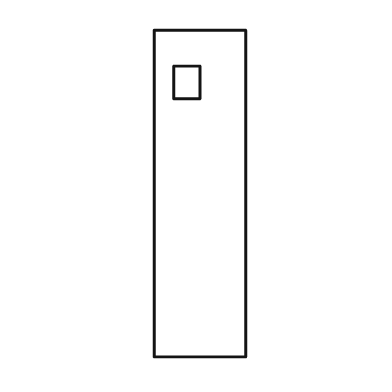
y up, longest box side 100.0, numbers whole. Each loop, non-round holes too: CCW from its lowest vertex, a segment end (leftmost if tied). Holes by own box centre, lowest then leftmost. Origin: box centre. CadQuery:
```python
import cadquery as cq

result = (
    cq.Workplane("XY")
    .moveTo(-14.0, -50.0)
    .lineTo(14.0, -50.0)
    .lineTo(14.0, 50.0)
    .lineTo(-14.0, 50.0)
    .close()
    .moveTo(-8.0, 29.0)
    .lineTo(0.0, 29.0)
    .lineTo(0.0, 39.0)
    .lineTo(-8.0, 39.0)
    .close()
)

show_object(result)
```